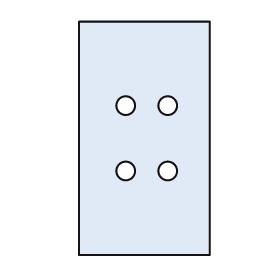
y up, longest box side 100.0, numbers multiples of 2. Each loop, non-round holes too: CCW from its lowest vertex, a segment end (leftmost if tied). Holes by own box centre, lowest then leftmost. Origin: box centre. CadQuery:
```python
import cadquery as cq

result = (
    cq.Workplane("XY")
    .moveTo(-28.0, -50.0)
    .lineTo(28.0, -50.0)
    .lineTo(28.0, 50.0)
    .lineTo(-28.0, 50.0)
    .close()
    .moveTo(-8.0, -14.0)
    .circle(4.0)
    .moveTo(10.0, -14.0)
    .circle(4.0)
    .moveTo(-8.0, 14.0)
    .circle(4.0)
    .moveTo(10.0, 14.0)
    .circle(4.0)
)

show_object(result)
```